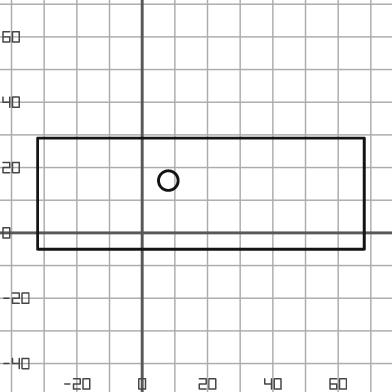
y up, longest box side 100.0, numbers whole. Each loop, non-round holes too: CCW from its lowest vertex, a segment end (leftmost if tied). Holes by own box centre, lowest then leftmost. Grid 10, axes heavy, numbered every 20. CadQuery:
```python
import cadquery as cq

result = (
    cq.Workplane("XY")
    .moveTo(-32.0, -5.0)
    .lineTo(68.0, -5.0)
    .lineTo(68.0, 29.0)
    .lineTo(-32.0, 29.0)
    .close()
    .moveTo(8.0, 16.0)
    .circle(3.0)
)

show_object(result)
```